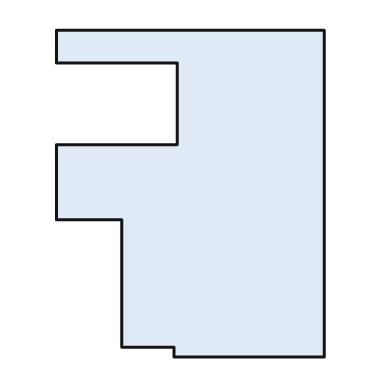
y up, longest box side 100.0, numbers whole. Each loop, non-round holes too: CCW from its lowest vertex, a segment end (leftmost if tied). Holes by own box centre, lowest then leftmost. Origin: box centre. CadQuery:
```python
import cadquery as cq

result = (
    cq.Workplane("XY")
    .moveTo(-5.0, -50.0)
    .lineTo(41.0, -50.0)
    .lineTo(41.0, 50.0)
    .lineTo(-41.0, 50.0)
    .lineTo(-41.0, 40.0)
    .lineTo(-4.0, 40.0)
    .lineTo(-4.0, 15.0)
    .lineTo(-41.0, 15.0)
    .lineTo(-41.0, -8.0)
    .lineTo(-21.0, -8.0)
    .lineTo(-21.0, -47.0)
    .lineTo(-5.0, -47.0)
    .close()
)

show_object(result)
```